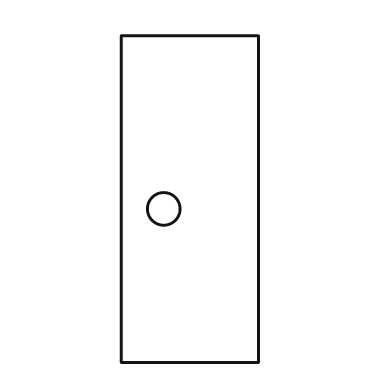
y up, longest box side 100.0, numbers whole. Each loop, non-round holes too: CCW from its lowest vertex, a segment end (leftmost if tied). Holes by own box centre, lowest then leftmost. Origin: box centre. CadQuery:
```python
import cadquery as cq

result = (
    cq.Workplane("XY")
    .moveTo(-21.0, -50.0)
    .lineTo(21.0, -50.0)
    .lineTo(21.0, 50.0)
    .lineTo(-21.0, 50.0)
    .close()
    .moveTo(-8.0, -3.0)
    .circle(5.0)
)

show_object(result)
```